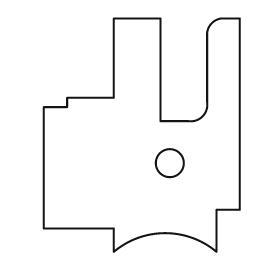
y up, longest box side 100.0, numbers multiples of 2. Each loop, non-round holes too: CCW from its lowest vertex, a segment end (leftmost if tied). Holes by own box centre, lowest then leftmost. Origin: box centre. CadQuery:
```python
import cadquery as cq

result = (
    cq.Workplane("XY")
    .moveTo(-12.0, -50.0)
    .threePointArc((10.0, -42.0), (32.0, -50.0))
    .lineTo(32.0, -32.0)
    .lineTo(42.0, -32.0)
    .lineTo(42.0, 50.0)
    .lineTo(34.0, 50.0)
    .threePointArc((30.0, 48.0), (28.0, 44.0))
    .lineTo(28.0, 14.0)
    .threePointArc((26.0, 8.0), (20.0, 6.0))
    .lineTo(8.0, 6.0)
    .lineTo(8.0, 50.0)
    .lineTo(-12.0, 50.0)
    .lineTo(-12.0, 16.0)
    .lineTo(-32.0, 16.0)
    .lineTo(-32.0, 12.0)
    .lineTo(-42.0, 12.0)
    .lineTo(-42.0, -40.0)
    .lineTo(-12.0, -40.0)
    .close()
    .moveTo(12.0, -12.0)
    .circle(6.0)
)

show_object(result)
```